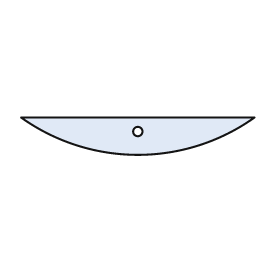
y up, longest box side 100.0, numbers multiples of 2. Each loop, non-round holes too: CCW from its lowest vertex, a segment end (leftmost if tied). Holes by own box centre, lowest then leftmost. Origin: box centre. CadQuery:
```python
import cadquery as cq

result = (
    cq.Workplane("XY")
    .moveTo(-50.0, 8.0)
    .threePointArc((0.0, -8.0), (50.0, 8.0))
    .close()
    .moveTo(0.0, 2.0)
    .circle(2.0)
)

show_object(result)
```